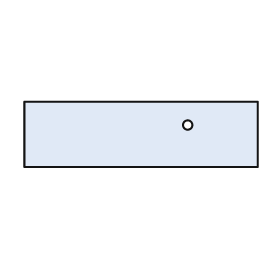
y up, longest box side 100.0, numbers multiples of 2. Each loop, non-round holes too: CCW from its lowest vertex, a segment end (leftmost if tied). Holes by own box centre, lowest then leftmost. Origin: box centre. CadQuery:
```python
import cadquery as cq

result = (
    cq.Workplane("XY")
    .moveTo(-50.0, -14.0)
    .lineTo(50.0, -14.0)
    .lineTo(50.0, 14.0)
    .lineTo(-50.0, 14.0)
    .close()
    .moveTo(20.0, 4.0)
    .circle(2.0)
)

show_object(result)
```